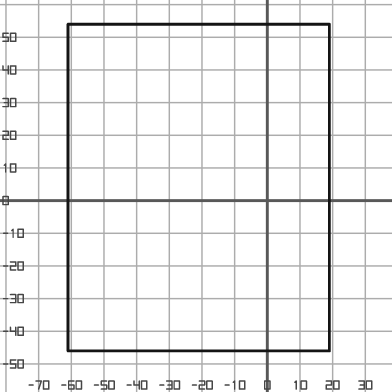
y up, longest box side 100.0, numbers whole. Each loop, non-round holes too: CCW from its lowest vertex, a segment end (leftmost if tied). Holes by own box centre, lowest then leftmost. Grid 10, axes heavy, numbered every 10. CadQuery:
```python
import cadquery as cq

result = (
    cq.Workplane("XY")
    .moveTo(-61.0, -46.0)
    .lineTo(19.0, -46.0)
    .lineTo(19.0, 54.0)
    .lineTo(-61.0, 54.0)
    .close()
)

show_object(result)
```